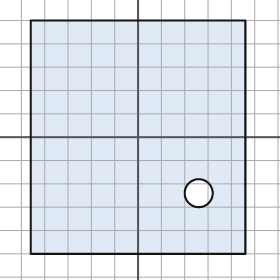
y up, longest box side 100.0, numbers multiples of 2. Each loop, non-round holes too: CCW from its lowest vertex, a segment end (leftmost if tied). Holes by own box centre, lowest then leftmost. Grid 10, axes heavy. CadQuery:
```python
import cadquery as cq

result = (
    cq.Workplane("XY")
    .moveTo(-46.0, -50.0)
    .lineTo(46.0, -50.0)
    .lineTo(46.0, 50.0)
    .lineTo(-46.0, 50.0)
    .close()
    .moveTo(26.0, -24.0)
    .circle(6.0)
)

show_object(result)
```